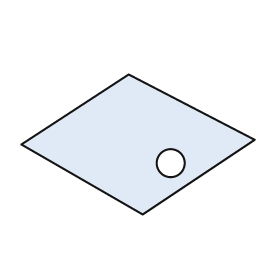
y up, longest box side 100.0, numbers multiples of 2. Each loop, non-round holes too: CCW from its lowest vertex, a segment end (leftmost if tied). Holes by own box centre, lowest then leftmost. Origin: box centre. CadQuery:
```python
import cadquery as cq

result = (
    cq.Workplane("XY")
    .moveTo(2.0, -30.0)
    .lineTo(50.0, 2.0)
    .lineTo(-4.0, 30.0)
    .lineTo(-50.0, 0.0)
    .close()
    .moveTo(14.0, -8.0)
    .circle(6.0)
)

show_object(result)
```